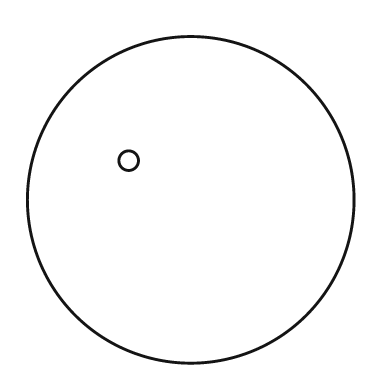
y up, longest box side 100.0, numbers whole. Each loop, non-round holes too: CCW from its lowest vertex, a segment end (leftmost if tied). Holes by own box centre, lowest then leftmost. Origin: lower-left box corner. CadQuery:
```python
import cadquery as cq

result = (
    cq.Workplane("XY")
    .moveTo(50.0, 50.0)
    .circle(50.0)
    .moveTo(31.0, 62.0)
    .circle(3.0)
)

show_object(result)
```